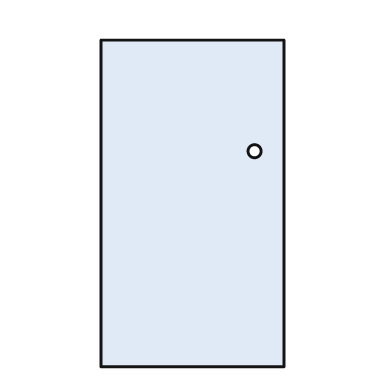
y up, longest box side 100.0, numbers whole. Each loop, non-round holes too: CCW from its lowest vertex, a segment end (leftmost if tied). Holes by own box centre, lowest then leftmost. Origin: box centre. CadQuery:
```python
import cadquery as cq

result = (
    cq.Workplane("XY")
    .moveTo(-28.0, -50.0)
    .lineTo(28.0, -50.0)
    .lineTo(28.0, 50.0)
    .lineTo(-28.0, 50.0)
    .close()
    .moveTo(19.0, 16.0)
    .circle(2.0)
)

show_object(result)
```